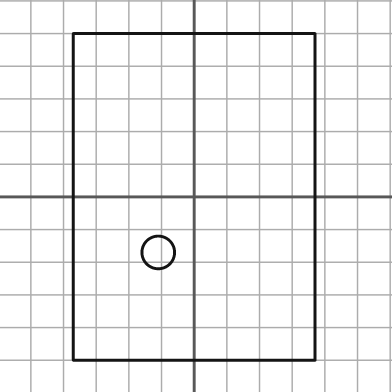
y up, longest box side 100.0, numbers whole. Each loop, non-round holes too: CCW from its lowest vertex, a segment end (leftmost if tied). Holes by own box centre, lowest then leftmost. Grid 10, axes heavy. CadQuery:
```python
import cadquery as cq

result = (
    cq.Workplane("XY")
    .moveTo(-37.0, -50.0)
    .lineTo(37.0, -50.0)
    .lineTo(37.0, 50.0)
    .lineTo(-37.0, 50.0)
    .close()
    .moveTo(-11.0, -17.0)
    .circle(5.0)
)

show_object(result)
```